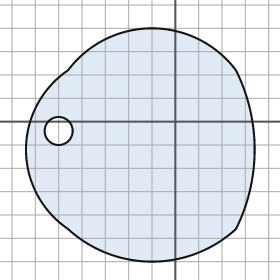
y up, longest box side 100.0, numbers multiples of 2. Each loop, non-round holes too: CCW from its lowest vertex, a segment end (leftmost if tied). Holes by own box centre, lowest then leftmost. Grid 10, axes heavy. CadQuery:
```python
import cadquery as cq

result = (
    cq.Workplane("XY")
    .moveTo(-46.0, -46.0)
    .threePointArc((-10.0, -60.0), (26.0, -46.0))
    .threePointArc((34.0, -12.0), (26.0, 22.0))
    .threePointArc((-10.0, 40.0), (-46.0, 22.0))
    .threePointArc((-64.0, -12.0), (-46.0, -46.0))
    .close()
    .moveTo(-50.0, -4.0)
    .circle(6.0)
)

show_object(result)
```